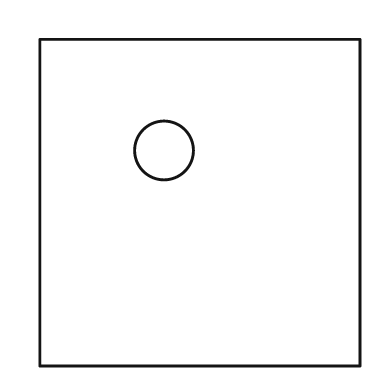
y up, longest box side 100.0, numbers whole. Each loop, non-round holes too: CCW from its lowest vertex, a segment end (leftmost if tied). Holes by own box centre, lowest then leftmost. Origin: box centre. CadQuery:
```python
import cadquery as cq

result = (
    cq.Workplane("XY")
    .moveTo(-49.0, -50.0)
    .lineTo(49.0, -50.0)
    .lineTo(49.0, 50.0)
    .lineTo(-49.0, 50.0)
    .close()
    .moveTo(-11.0, 16.0)
    .circle(9.0)
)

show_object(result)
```